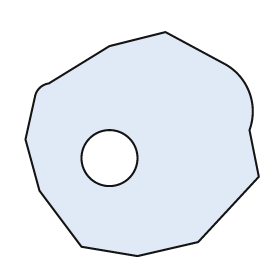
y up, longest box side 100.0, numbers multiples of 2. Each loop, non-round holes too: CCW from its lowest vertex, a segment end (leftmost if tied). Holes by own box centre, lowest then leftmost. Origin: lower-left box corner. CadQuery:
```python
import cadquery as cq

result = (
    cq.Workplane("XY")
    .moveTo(48.0, 0.0)
    .lineTo(74.0, 6.0)
    .lineTo(100.0, 34.0)
    .lineTo(96.0, 54.0)
    .threePointArc((96.0, 70.0), (86.0, 82.0))
    .lineTo(60.0, 96.0)
    .lineTo(36.0, 90.0)
    .lineTo(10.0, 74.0)
    .threePointArc((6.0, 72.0), (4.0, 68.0))
    .lineTo(0.0, 50.0)
    .lineTo(6.0, 28.0)
    .lineTo(24.0, 4.0)
    .close()
    .moveTo(36.0, 42.0)
    .circle(12.0)
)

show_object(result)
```